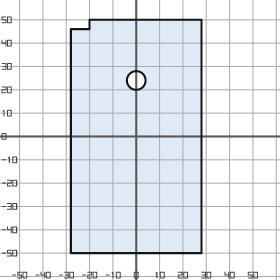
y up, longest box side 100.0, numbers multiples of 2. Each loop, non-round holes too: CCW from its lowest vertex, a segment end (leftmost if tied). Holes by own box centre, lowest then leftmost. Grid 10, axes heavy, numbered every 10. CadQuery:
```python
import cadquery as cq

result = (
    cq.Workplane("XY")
    .moveTo(-28.0, -50.0)
    .lineTo(28.0, -50.0)
    .lineTo(28.0, 50.0)
    .lineTo(-20.0, 50.0)
    .lineTo(-20.0, 46.0)
    .lineTo(-28.0, 46.0)
    .close()
    .moveTo(0.0, 24.0)
    .circle(4.0)
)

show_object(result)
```